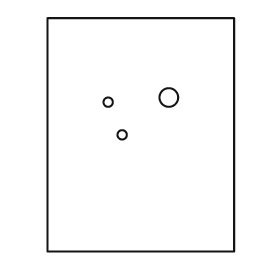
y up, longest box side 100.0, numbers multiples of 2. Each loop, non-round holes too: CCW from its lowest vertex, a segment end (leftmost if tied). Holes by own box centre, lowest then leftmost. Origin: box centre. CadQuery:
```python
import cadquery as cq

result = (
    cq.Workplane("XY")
    .moveTo(-40.0, -50.0)
    .lineTo(40.0, -50.0)
    .lineTo(40.0, 50.0)
    .lineTo(-40.0, 50.0)
    .close()
    .moveTo(-8.0, 0.0)
    .circle(2.0)
    .moveTo(-14.0, 14.0)
    .circle(2.0)
    .moveTo(12.0, 16.0)
    .circle(4.0)
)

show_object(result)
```